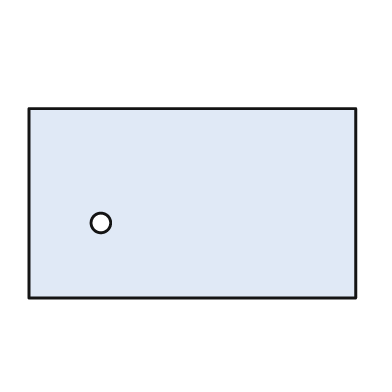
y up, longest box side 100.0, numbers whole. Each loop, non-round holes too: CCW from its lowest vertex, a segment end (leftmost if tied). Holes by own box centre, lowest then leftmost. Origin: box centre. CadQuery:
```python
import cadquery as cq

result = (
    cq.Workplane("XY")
    .moveTo(-50.0, -29.0)
    .lineTo(50.0, -29.0)
    .lineTo(50.0, 29.0)
    .lineTo(-50.0, 29.0)
    .close()
    .moveTo(-28.0, -6.0)
    .circle(3.0)
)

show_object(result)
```